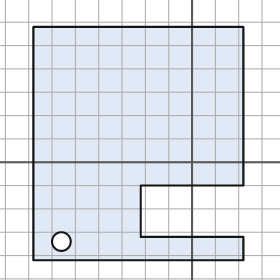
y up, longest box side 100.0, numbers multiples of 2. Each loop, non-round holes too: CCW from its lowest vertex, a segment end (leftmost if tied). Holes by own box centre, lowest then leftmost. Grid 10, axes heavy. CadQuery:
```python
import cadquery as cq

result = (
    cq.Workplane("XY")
    .moveTo(-68.0, -42.0)
    .lineTo(22.0, -42.0)
    .lineTo(22.0, -32.0)
    .lineTo(-22.0, -32.0)
    .lineTo(-22.0, -10.0)
    .lineTo(22.0, -10.0)
    .lineTo(22.0, 58.0)
    .lineTo(-68.0, 58.0)
    .close()
    .moveTo(-56.0, -34.0)
    .circle(4.0)
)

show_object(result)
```